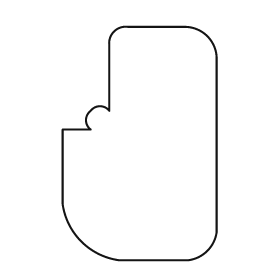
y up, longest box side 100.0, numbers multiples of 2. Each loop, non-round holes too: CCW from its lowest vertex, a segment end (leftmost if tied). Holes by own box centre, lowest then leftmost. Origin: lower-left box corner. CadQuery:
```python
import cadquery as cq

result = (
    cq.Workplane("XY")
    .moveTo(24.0, 0.0)
    .lineTo(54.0, 0.0)
    .threePointArc((62.0, 4.0), (66.0, 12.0))
    .lineTo(66.0, 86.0)
    .threePointArc((62.0, 96.0), (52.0, 100.0))
    .lineTo(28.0, 100.0)
    .threePointArc((22.0, 98.0), (20.0, 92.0))
    .lineTo(20.0, 64.0)
    .threePointArc((16.0, 66.0), (12.0, 64.0))
    .threePointArc((10.0, 60.0), (12.0, 56.0))
    .lineTo(0.0, 56.0)
    .lineTo(0.0, 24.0)
    .threePointArc((8.0, 8.0), (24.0, 0.0))
    .close()
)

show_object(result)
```